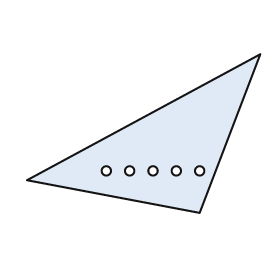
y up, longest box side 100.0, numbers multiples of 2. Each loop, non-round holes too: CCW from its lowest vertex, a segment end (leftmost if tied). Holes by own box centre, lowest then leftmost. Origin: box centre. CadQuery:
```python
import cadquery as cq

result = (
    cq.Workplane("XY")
    .moveTo(24.0, -34.0)
    .lineTo(50.0, 34.0)
    .lineTo(-50.0, -20.0)
    .close()
    .moveTo(-16.0, -16.0)
    .circle(2.0)
    .moveTo(-6.0, -16.0)
    .circle(2.0)
    .moveTo(4.0, -16.0)
    .circle(2.0)
    .moveTo(14.0, -16.0)
    .circle(2.0)
    .moveTo(24.0, -16.0)
    .circle(2.0)
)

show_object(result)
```